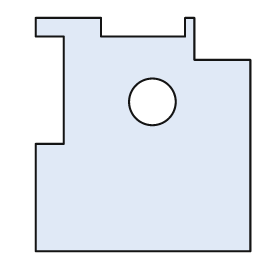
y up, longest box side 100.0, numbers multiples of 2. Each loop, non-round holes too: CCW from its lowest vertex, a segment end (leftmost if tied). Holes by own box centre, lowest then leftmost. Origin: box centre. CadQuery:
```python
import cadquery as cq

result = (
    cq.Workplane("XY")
    .moveTo(-46.0, -50.0)
    .lineTo(46.0, -50.0)
    .lineTo(46.0, 32.0)
    .lineTo(22.0, 32.0)
    .lineTo(22.0, 50.0)
    .lineTo(18.0, 50.0)
    .lineTo(18.0, 42.0)
    .lineTo(-18.0, 42.0)
    .lineTo(-18.0, 50.0)
    .lineTo(-46.0, 50.0)
    .lineTo(-46.0, 42.0)
    .lineTo(-34.0, 42.0)
    .lineTo(-34.0, -4.0)
    .lineTo(-46.0, -4.0)
    .close()
    .moveTo(4.0, 14.0)
    .circle(10.0)
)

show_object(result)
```